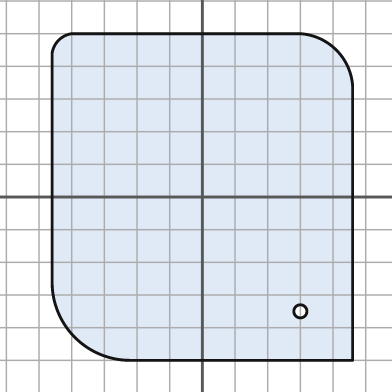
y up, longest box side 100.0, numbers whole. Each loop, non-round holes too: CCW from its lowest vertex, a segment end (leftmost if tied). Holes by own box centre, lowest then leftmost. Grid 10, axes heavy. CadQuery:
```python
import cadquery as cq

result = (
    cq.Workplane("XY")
    .moveTo(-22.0, -50.0)
    .lineTo(46.0, -50.0)
    .lineTo(46.0, 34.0)
    .threePointArc((41.0, 45.0), (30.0, 50.0))
    .lineTo(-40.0, 50.0)
    .threePointArc((-44.0, 48.0), (-46.0, 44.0))
    .lineTo(-46.0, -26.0)
    .threePointArc((-39.0, -43.0), (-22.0, -50.0))
    .close()
    .moveTo(30.0, -35.0)
    .circle(2.0)
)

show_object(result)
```